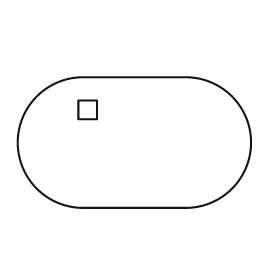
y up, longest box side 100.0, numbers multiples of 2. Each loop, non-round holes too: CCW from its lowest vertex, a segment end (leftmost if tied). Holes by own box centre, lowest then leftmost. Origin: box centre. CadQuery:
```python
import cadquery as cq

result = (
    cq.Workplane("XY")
    .moveTo(-22.0, -28.0)
    .lineTo(22.0, -28.0)
    .threePointArc((50.0, 0.0), (22.0, 28.0))
    .lineTo(-22.0, 28.0)
    .threePointArc((-50.0, 0.0), (-22.0, -28.0))
    .close()
    .moveTo(-24.0, 10.0)
    .lineTo(-16.0, 10.0)
    .lineTo(-16.0, 18.0)
    .lineTo(-24.0, 18.0)
    .close()
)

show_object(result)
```